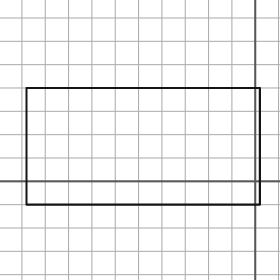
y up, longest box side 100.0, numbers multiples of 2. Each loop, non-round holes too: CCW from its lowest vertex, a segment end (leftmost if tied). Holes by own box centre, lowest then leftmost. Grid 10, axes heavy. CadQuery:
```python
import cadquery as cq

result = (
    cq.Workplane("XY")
    .moveTo(-98.0, -10.0)
    .lineTo(2.0, -10.0)
    .lineTo(2.0, 40.0)
    .lineTo(-98.0, 40.0)
    .close()
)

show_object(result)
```